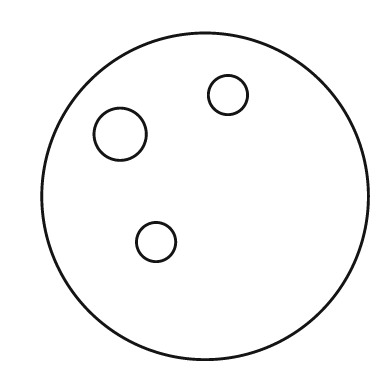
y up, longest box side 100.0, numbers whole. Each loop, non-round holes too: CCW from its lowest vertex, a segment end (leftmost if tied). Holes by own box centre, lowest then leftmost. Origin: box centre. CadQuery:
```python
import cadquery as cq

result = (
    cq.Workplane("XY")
    .moveTo(0.0, 0.0)
    .circle(50.0)
    .moveTo(-15.0, -14.0)
    .circle(6.0)
    .moveTo(-26.0, 19.0)
    .circle(8.0)
    .moveTo(7.0, 31.0)
    .circle(6.0)
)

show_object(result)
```